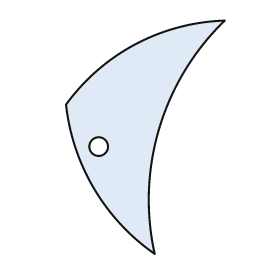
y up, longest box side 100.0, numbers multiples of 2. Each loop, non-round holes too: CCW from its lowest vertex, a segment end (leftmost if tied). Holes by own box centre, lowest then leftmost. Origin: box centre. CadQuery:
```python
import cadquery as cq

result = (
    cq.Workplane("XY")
    .moveTo(4.0, -50.0)
    .threePointArc((6.0, 4.0), (34.0, 50.0))
    .threePointArc((-4.0, 40.0), (-34.0, 14.0))
    .threePointArc((-22.0, -22.0), (4.0, -50.0))
    .close()
    .moveTo(-20.0, -4.0)
    .circle(4.0)
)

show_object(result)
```